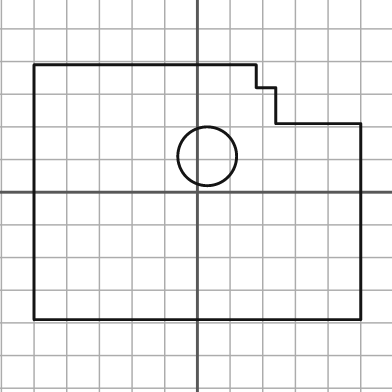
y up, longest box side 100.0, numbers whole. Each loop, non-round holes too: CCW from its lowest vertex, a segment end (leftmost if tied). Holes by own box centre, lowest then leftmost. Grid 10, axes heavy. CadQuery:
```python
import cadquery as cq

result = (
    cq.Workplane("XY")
    .moveTo(-50.0, -39.0)
    .lineTo(50.0, -39.0)
    .lineTo(50.0, 21.0)
    .lineTo(24.0, 21.0)
    .lineTo(24.0, 32.0)
    .lineTo(18.0, 32.0)
    .lineTo(18.0, 39.0)
    .lineTo(-50.0, 39.0)
    .close()
    .moveTo(3.0, 11.0)
    .circle(9.0)
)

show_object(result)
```